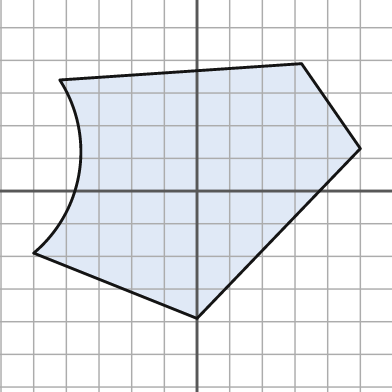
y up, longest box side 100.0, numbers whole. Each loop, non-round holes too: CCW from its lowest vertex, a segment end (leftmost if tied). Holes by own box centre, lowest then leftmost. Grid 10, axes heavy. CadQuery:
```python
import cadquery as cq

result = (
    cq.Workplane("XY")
    .moveTo(0.0, -39.0)
    .lineTo(50.0, 13.0)
    .lineTo(32.0, 39.0)
    .lineTo(-42.0, 34.0)
    .threePointArc((-36.0, 6.0), (-50.0, -19.0))
    .close()
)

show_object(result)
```